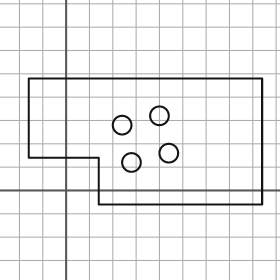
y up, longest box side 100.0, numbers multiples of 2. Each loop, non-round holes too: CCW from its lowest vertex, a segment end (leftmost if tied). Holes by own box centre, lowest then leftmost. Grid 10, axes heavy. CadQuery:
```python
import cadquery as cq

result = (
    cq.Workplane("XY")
    .moveTo(14.0, -6.0)
    .lineTo(84.0, -6.0)
    .lineTo(84.0, 48.0)
    .lineTo(-16.0, 48.0)
    .lineTo(-16.0, 14.0)
    .lineTo(14.0, 14.0)
    .close()
    .moveTo(28.0, 12.0)
    .circle(4.0)
    .moveTo(44.0, 16.0)
    .circle(4.0)
    .moveTo(24.0, 28.0)
    .circle(4.0)
    .moveTo(40.0, 32.0)
    .circle(4.0)
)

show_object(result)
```